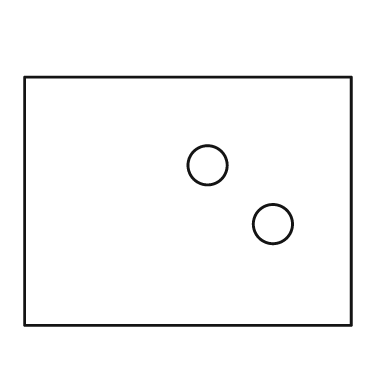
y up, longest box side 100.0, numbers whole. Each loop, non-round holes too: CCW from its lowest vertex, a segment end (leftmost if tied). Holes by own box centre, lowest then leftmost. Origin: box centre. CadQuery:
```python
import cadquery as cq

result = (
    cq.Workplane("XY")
    .moveTo(-50.0, -38.0)
    .lineTo(50.0, -38.0)
    .lineTo(50.0, 38.0)
    .lineTo(-50.0, 38.0)
    .close()
    .moveTo(26.0, -7.0)
    .circle(6.0)
    .moveTo(6.0, 11.0)
    .circle(6.0)
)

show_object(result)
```